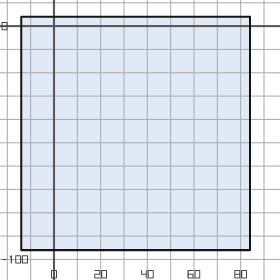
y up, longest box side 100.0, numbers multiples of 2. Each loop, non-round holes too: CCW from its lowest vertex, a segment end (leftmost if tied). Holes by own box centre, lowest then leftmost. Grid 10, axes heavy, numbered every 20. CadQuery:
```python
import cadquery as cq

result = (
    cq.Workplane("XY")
    .moveTo(-14.0, -96.0)
    .lineTo(84.0, -96.0)
    .lineTo(84.0, 4.0)
    .lineTo(-14.0, 4.0)
    .close()
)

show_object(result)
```